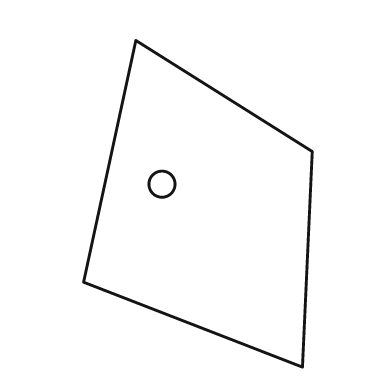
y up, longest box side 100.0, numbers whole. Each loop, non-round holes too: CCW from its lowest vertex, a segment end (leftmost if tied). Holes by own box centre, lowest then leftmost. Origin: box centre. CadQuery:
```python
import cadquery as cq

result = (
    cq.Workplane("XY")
    .moveTo(32.0, -50.0)
    .lineTo(35.0, 16.0)
    .lineTo(-19.0, 50.0)
    .lineTo(-35.0, -24.0)
    .close()
    .moveTo(-11.0, 6.0)
    .circle(4.0)
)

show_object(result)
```